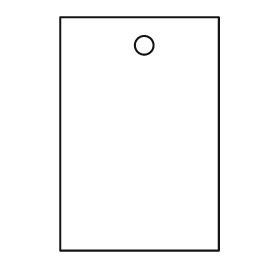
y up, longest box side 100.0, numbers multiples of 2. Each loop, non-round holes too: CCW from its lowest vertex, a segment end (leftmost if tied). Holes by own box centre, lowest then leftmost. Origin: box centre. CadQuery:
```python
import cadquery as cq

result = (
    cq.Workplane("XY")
    .moveTo(-34.0, -50.0)
    .lineTo(34.0, -50.0)
    .lineTo(34.0, 50.0)
    .lineTo(-34.0, 50.0)
    .close()
    .moveTo(2.0, 38.0)
    .circle(4.0)
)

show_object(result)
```